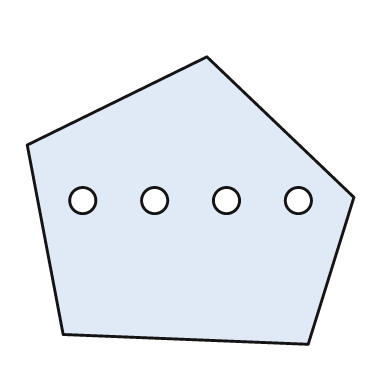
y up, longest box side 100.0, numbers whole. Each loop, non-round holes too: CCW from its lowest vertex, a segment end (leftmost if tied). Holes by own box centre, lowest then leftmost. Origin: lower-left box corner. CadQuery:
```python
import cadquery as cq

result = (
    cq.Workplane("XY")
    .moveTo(86.0, 0.0)
    .lineTo(100.0, 45.0)
    .lineTo(55.0, 88.0)
    .lineTo(0.0, 61.0)
    .lineTo(11.0, 3.0)
    .close()
    .moveTo(17.0, 44.0)
    .circle(4.0)
    .moveTo(39.0, 44.0)
    .circle(4.0)
    .moveTo(61.0, 44.0)
    .circle(4.0)
    .moveTo(83.0, 44.0)
    .circle(4.0)
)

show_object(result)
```